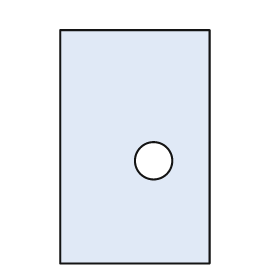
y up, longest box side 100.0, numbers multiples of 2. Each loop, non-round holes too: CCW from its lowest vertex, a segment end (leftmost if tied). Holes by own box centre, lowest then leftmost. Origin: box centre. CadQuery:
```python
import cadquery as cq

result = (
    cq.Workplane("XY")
    .moveTo(-32.0, -50.0)
    .lineTo(32.0, -50.0)
    .lineTo(32.0, 50.0)
    .lineTo(-32.0, 50.0)
    .close()
    .moveTo(8.0, -6.0)
    .circle(8.0)
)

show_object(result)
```